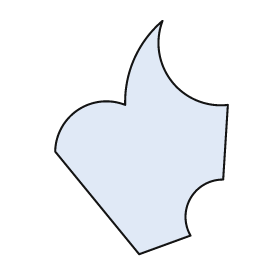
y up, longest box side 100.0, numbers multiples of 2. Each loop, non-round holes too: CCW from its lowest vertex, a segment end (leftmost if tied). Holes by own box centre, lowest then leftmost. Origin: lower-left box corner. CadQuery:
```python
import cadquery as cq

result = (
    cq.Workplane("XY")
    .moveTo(36.0, 0.0)
    .lineTo(58.0, 8.0)
    .threePointArc((58.0, 24.0), (72.0, 32.0))
    .lineTo(74.0, 64.0)
    .threePointArc((50.0, 74.0), (46.0, 100.0))
    .threePointArc((34.0, 84.0), (30.0, 64.0))
    .threePointArc((10.0, 62.0), (0.0, 44.0))
    .close()
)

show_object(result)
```